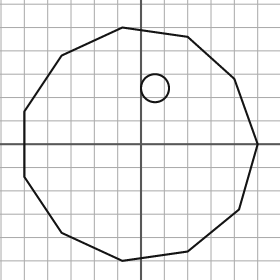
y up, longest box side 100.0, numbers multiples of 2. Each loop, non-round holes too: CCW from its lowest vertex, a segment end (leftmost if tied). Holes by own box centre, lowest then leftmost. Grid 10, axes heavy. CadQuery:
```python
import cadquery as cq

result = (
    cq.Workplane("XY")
    .moveTo(-8.0, -50.0)
    .lineTo(20.0, -46.0)
    .lineTo(42.0, -28.0)
    .lineTo(50.0, 0.0)
    .lineTo(40.0, 28.0)
    .lineTo(20.0, 46.0)
    .lineTo(-8.0, 50.0)
    .lineTo(-34.0, 38.0)
    .lineTo(-50.0, 14.0)
    .lineTo(-50.0, -14.0)
    .lineTo(-34.0, -38.0)
    .close()
    .moveTo(6.0, 24.0)
    .circle(6.0)
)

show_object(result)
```